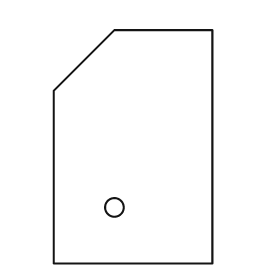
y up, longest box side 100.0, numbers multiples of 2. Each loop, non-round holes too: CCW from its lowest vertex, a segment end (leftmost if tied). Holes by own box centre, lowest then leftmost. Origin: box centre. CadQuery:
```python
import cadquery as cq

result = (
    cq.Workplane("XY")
    .moveTo(-34.0, -50.0)
    .lineTo(34.0, -50.0)
    .lineTo(34.0, 50.0)
    .lineTo(-8.0, 50.0)
    .lineTo(-34.0, 24.0)
    .close()
    .moveTo(-8.0, -26.0)
    .circle(4.0)
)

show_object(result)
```